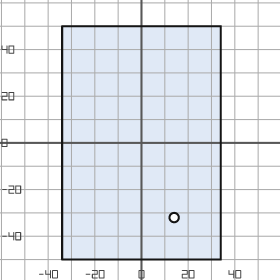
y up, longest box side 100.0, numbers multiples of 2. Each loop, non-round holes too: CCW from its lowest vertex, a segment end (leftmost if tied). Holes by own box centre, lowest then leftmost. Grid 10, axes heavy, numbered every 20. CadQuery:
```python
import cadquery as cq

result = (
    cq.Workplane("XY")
    .moveTo(-34.0, -50.0)
    .lineTo(34.0, -50.0)
    .lineTo(34.0, 50.0)
    .lineTo(-34.0, 50.0)
    .close()
    .moveTo(14.0, -32.0)
    .circle(2.0)
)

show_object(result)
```